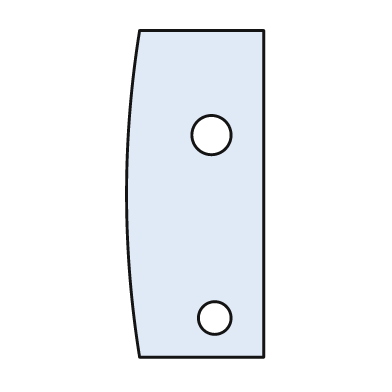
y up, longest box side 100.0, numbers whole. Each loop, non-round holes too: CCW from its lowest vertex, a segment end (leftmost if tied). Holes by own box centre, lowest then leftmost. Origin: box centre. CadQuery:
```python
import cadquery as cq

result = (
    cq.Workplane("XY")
    .moveTo(-17.0, -50.0)
    .lineTo(21.0, -50.0)
    .lineTo(21.0, 50.0)
    .lineTo(-17.0, 50.0)
    .threePointArc((-21.0, 0.0), (-17.0, -50.0))
    .close()
    .moveTo(6.0, -38.0)
    .circle(5.0)
    .moveTo(5.0, 18.0)
    .circle(6.0)
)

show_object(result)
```